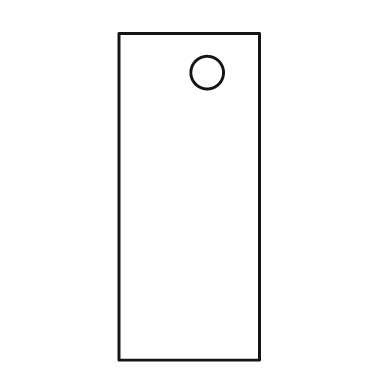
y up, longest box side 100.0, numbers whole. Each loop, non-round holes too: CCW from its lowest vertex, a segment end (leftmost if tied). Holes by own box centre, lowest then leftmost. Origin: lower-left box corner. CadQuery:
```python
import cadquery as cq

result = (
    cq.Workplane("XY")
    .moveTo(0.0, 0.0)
    .lineTo(43.0, 0.0)
    .lineTo(43.0, 100.0)
    .lineTo(0.0, 100.0)
    .close()
    .moveTo(27.0, 88.0)
    .circle(5.0)
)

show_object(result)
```